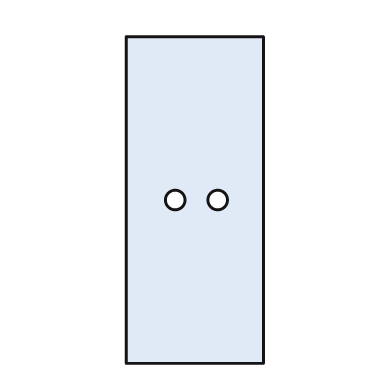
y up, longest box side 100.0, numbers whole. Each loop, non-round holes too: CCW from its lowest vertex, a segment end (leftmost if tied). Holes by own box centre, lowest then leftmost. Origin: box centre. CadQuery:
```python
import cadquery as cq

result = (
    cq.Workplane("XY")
    .moveTo(-21.0, -50.0)
    .lineTo(21.0, -50.0)
    .lineTo(21.0, 50.0)
    .lineTo(-21.0, 50.0)
    .close()
    .moveTo(-6.0, 0.0)
    .circle(3.0)
    .moveTo(7.0, 0.0)
    .circle(3.0)
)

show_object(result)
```